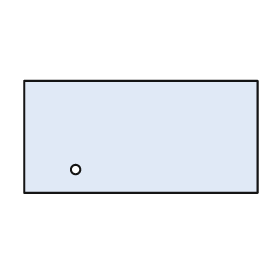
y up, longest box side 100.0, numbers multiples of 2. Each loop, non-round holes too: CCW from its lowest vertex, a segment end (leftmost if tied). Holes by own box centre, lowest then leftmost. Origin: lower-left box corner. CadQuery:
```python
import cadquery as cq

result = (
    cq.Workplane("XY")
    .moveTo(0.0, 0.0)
    .lineTo(100.0, 0.0)
    .lineTo(100.0, 48.0)
    .lineTo(0.0, 48.0)
    .close()
    .moveTo(22.0, 10.0)
    .circle(2.0)
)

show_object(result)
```